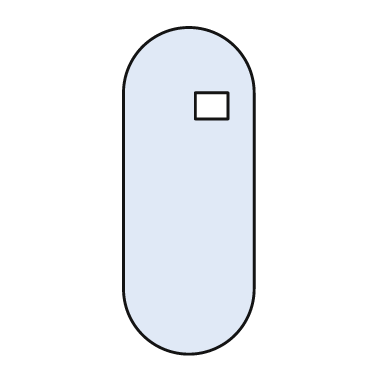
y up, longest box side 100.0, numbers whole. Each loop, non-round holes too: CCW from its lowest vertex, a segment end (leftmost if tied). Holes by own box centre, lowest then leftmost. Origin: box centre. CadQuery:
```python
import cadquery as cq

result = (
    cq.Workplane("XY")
    .moveTo(-20.0, -30.0)
    .threePointArc((0.0, -50.0), (20.0, -30.0))
    .lineTo(20.0, 30.0)
    .threePointArc((0.0, 50.0), (-20.0, 30.0))
    .close()
    .moveTo(2.0, 22.0)
    .lineTo(12.0, 22.0)
    .lineTo(12.0, 30.0)
    .lineTo(2.0, 30.0)
    .close()
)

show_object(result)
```